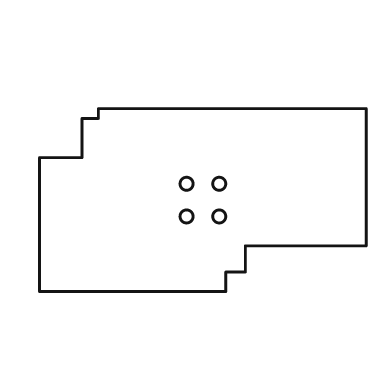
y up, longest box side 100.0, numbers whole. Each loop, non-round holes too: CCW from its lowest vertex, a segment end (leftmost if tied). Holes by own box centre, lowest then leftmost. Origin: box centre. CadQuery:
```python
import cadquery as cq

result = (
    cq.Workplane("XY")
    .moveTo(-50.0, -28.0)
    .lineTo(7.0, -28.0)
    .lineTo(7.0, -22.0)
    .lineTo(13.0, -22.0)
    .lineTo(13.0, -14.0)
    .lineTo(50.0, -14.0)
    .lineTo(50.0, 28.0)
    .lineTo(-32.0, 28.0)
    .lineTo(-32.0, 25.0)
    .lineTo(-37.0, 25.0)
    .lineTo(-37.0, 13.0)
    .lineTo(-50.0, 13.0)
    .close()
    .moveTo(-5.0, -5.0)
    .circle(2.0)
    .moveTo(5.0, -5.0)
    .circle(2.0)
    .moveTo(-5.0, 5.0)
    .circle(2.0)
    .moveTo(5.0, 5.0)
    .circle(2.0)
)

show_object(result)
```